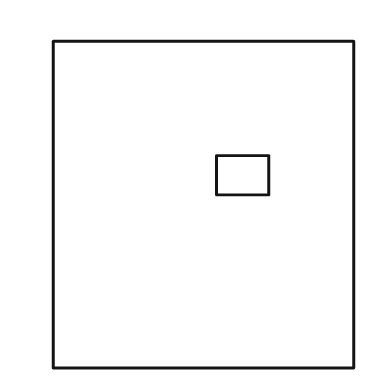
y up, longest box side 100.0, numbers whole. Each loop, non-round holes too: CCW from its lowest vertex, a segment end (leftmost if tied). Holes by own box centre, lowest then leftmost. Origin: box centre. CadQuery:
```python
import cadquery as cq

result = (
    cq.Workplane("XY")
    .moveTo(-46.0, -50.0)
    .lineTo(46.0, -50.0)
    .lineTo(46.0, 50.0)
    .lineTo(-46.0, 50.0)
    .close()
    .moveTo(4.0, 3.0)
    .lineTo(20.0, 3.0)
    .lineTo(20.0, 15.0)
    .lineTo(4.0, 15.0)
    .close()
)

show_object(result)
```